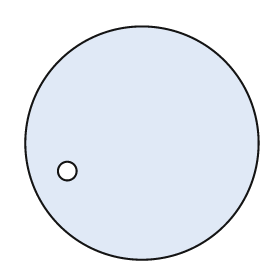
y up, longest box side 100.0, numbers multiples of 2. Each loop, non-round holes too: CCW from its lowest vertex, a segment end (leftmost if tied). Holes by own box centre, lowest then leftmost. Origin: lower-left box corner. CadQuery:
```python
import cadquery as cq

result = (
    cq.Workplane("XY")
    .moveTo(50.0, 50.0)
    .circle(50.0)
    .moveTo(18.0, 38.0)
    .circle(4.0)
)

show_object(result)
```